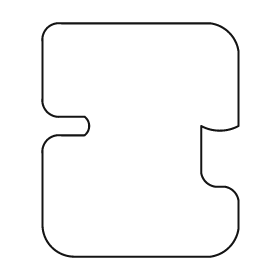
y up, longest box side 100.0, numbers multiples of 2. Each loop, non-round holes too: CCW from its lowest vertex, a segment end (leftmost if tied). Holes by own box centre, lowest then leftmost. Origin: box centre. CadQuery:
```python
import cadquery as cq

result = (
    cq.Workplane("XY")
    .moveTo(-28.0, -50.0)
    .lineTo(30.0, -50.0)
    .threePointArc((38.0, -46.0), (42.0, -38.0))
    .lineTo(42.0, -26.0)
    .threePointArc((40.0, -22.0), (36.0, -20.0))
    .lineTo(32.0, -20.0)
    .threePointArc((28.0, -18.0), (26.0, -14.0))
    .lineTo(26.0, 6.0)
    .threePointArc((34.0, 4.0), (42.0, 6.0))
    .lineTo(42.0, 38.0)
    .threePointArc((38.0, 46.0), (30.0, 50.0))
    .lineTo(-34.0, 50.0)
    .threePointArc((-40.0, 48.0), (-42.0, 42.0))
    .lineTo(-42.0, 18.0)
    .threePointArc((-40.0, 12.0), (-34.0, 10.0))
    .lineTo(-24.0, 10.0)
    .threePointArc((-22.0, 6.0), (-24.0, 2.0))
    .lineTo(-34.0, 2.0)
    .threePointArc((-40.0, 0.0), (-42.0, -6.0))
    .lineTo(-42.0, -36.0)
    .threePointArc((-38.0, -46.0), (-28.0, -50.0))
    .close()
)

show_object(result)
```